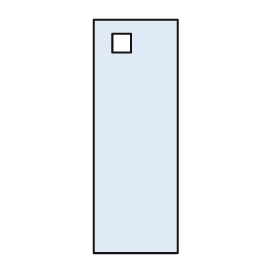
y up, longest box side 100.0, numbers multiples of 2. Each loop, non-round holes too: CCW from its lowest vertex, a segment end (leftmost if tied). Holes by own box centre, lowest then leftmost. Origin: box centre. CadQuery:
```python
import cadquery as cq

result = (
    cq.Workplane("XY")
    .moveTo(-18.0, -50.0)
    .lineTo(18.0, -50.0)
    .lineTo(18.0, 50.0)
    .lineTo(-18.0, 50.0)
    .close()
    .moveTo(-10.0, 36.0)
    .lineTo(-2.0, 36.0)
    .lineTo(-2.0, 44.0)
    .lineTo(-10.0, 44.0)
    .close()
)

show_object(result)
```